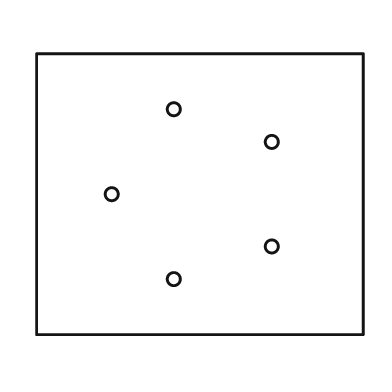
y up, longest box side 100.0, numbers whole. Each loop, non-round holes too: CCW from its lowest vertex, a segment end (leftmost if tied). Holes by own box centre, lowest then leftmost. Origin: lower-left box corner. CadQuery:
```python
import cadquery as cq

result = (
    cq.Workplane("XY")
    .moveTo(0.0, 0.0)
    .lineTo(100.0, 0.0)
    .lineTo(100.0, 86.0)
    .lineTo(0.0, 86.0)
    .close()
    .moveTo(42.0, 17.0)
    .circle(2.0)
    .moveTo(72.0, 27.0)
    .circle(2.0)
    .moveTo(23.0, 43.0)
    .circle(2.0)
    .moveTo(72.0, 59.0)
    .circle(2.0)
    .moveTo(42.0, 69.0)
    .circle(2.0)
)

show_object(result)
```